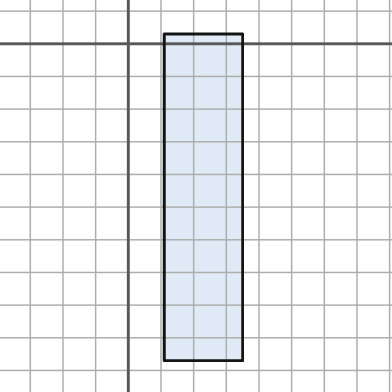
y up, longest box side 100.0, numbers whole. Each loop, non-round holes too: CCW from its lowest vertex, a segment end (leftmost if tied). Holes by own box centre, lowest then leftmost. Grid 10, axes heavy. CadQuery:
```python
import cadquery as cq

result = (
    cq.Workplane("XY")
    .moveTo(11.0, -97.0)
    .lineTo(35.0, -97.0)
    .lineTo(35.0, 3.0)
    .lineTo(11.0, 3.0)
    .close()
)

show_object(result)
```